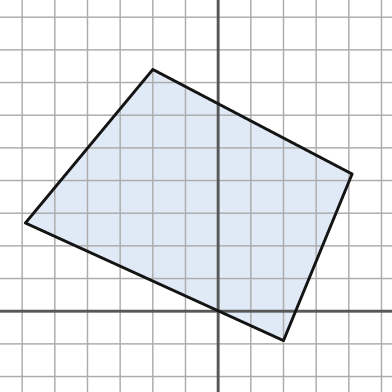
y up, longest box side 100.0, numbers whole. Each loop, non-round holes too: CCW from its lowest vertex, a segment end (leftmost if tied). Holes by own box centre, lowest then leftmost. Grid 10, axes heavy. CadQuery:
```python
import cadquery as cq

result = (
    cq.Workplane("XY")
    .moveTo(20.0, -9.0)
    .lineTo(41.0, 42.0)
    .lineTo(-20.0, 74.0)
    .lineTo(-59.0, 27.0)
    .close()
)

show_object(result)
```